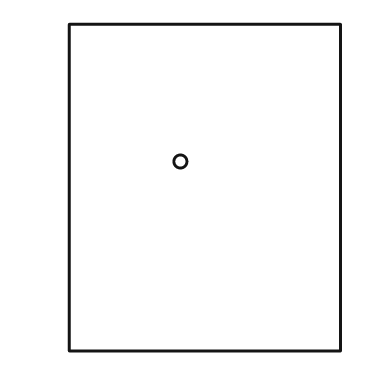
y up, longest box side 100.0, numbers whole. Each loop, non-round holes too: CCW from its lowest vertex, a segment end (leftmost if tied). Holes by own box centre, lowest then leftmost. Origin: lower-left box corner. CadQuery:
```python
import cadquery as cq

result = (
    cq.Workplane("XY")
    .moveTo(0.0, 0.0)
    .lineTo(83.0, 0.0)
    .lineTo(83.0, 100.0)
    .lineTo(0.0, 100.0)
    .close()
    .moveTo(34.0, 58.0)
    .circle(2.0)
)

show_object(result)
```